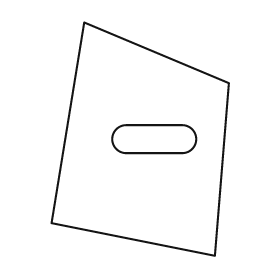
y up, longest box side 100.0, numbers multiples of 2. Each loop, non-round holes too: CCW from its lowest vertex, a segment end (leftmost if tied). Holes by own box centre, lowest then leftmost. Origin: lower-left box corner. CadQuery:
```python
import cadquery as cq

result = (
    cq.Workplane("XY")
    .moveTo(70.0, 0.0)
    .lineTo(76.0, 74.0)
    .lineTo(14.0, 100.0)
    .lineTo(0.0, 14.0)
    .close()
    .moveTo(32.0, 44.0)
    .lineTo(56.0, 44.0)
    .threePointArc((62.0, 50.0), (56.0, 56.0))
    .lineTo(32.0, 56.0)
    .threePointArc((26.0, 50.0), (32.0, 44.0))
    .close()
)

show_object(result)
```